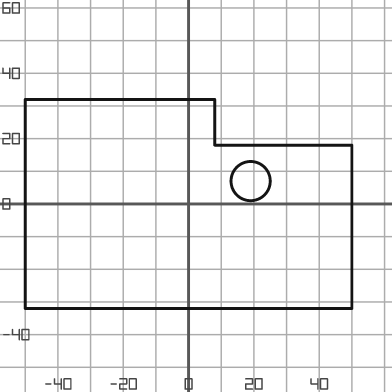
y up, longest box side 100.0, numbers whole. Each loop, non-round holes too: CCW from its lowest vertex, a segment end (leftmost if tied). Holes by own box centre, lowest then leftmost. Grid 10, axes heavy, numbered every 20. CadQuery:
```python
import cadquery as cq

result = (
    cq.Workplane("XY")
    .moveTo(-50.0, -32.0)
    .lineTo(50.0, -32.0)
    .lineTo(50.0, 18.0)
    .lineTo(8.0, 18.0)
    .lineTo(8.0, 32.0)
    .lineTo(-50.0, 32.0)
    .close()
    .moveTo(19.0, 7.0)
    .circle(6.0)
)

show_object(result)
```